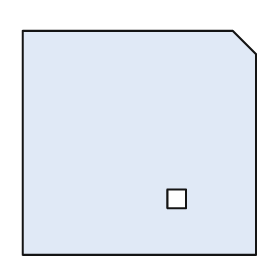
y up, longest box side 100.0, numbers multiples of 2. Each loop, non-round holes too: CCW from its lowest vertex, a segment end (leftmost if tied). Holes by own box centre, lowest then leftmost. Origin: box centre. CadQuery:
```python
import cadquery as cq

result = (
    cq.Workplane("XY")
    .moveTo(-50.0, -48.0)
    .lineTo(50.0, -48.0)
    .lineTo(50.0, 38.0)
    .lineTo(40.0, 48.0)
    .lineTo(-50.0, 48.0)
    .close()
    .moveTo(12.0, -28.0)
    .lineTo(20.0, -28.0)
    .lineTo(20.0, -20.0)
    .lineTo(12.0, -20.0)
    .close()
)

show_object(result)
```